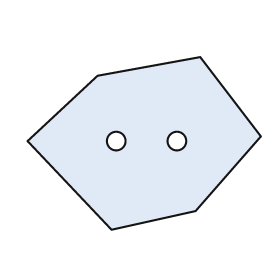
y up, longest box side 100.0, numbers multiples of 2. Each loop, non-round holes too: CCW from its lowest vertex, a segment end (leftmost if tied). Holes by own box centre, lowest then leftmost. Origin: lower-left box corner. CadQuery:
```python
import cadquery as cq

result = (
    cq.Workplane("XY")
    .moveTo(36.0, 0.0)
    .lineTo(72.0, 8.0)
    .lineTo(100.0, 40.0)
    .lineTo(74.0, 74.0)
    .lineTo(30.0, 66.0)
    .lineTo(0.0, 38.0)
    .close()
    .moveTo(38.0, 38.0)
    .circle(4.0)
    .moveTo(64.0, 38.0)
    .circle(4.0)
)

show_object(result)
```